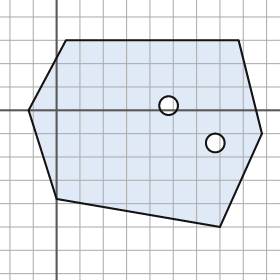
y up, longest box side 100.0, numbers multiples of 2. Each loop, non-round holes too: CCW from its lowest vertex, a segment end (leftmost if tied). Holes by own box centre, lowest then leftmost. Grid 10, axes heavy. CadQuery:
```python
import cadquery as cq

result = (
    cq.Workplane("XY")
    .moveTo(70.0, -50.0)
    .lineTo(88.0, -10.0)
    .lineTo(78.0, 30.0)
    .lineTo(4.0, 30.0)
    .lineTo(-12.0, 0.0)
    .lineTo(0.0, -38.0)
    .close()
    .moveTo(68.0, -14.0)
    .circle(4.0)
    .moveTo(48.0, 2.0)
    .circle(4.0)
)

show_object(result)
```